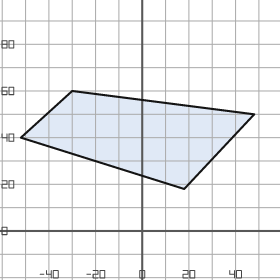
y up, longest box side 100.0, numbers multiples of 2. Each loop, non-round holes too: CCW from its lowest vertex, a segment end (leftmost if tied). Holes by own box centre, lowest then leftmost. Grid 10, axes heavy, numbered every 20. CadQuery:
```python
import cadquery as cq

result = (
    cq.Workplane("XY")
    .moveTo(18.0, 18.0)
    .lineTo(48.0, 50.0)
    .lineTo(-30.0, 60.0)
    .lineTo(-52.0, 40.0)
    .close()
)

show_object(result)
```